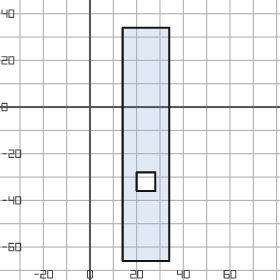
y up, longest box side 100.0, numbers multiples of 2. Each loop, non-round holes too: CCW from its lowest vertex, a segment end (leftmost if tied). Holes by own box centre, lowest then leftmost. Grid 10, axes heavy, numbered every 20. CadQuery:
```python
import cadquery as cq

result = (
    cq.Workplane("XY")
    .moveTo(14.0, -66.0)
    .lineTo(34.0, -66.0)
    .lineTo(34.0, 34.0)
    .lineTo(14.0, 34.0)
    .close()
    .moveTo(20.0, -36.0)
    .lineTo(28.0, -36.0)
    .lineTo(28.0, -28.0)
    .lineTo(20.0, -28.0)
    .close()
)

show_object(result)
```